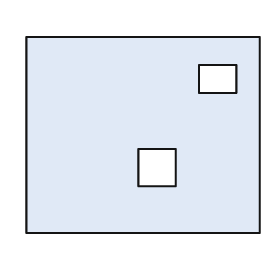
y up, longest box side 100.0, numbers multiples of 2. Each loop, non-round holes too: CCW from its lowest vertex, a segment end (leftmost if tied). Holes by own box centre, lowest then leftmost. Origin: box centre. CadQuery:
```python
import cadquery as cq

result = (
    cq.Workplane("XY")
    .moveTo(-50.0, -42.0)
    .lineTo(50.0, -42.0)
    .lineTo(50.0, 42.0)
    .lineTo(-50.0, 42.0)
    .close()
    .moveTo(-2.0, -22.0)
    .lineTo(14.0, -22.0)
    .lineTo(14.0, -6.0)
    .lineTo(-2.0, -6.0)
    .close()
    .moveTo(24.0, 18.0)
    .lineTo(40.0, 18.0)
    .lineTo(40.0, 30.0)
    .lineTo(24.0, 30.0)
    .close()
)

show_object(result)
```